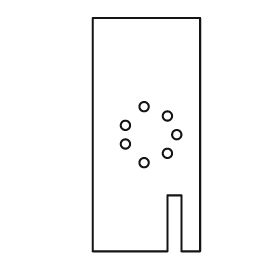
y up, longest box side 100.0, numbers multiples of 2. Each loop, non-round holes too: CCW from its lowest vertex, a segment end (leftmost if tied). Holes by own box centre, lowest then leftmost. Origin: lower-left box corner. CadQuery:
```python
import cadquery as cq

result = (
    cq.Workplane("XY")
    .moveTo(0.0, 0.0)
    .lineTo(32.0, 0.0)
    .lineTo(32.0, 24.0)
    .lineTo(38.0, 24.0)
    .lineTo(38.0, 0.0)
    .lineTo(46.0, 0.0)
    .lineTo(46.0, 100.0)
    .lineTo(0.0, 100.0)
    .close()
    .moveTo(22.0, 38.0)
    .circle(2.0)
    .moveTo(32.0, 42.0)
    .circle(2.0)
    .moveTo(14.0, 46.0)
    .circle(2.0)
    .moveTo(36.0, 50.0)
    .circle(2.0)
    .moveTo(14.0, 54.0)
    .circle(2.0)
    .moveTo(32.0, 58.0)
    .circle(2.0)
    .moveTo(22.0, 62.0)
    .circle(2.0)
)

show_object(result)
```